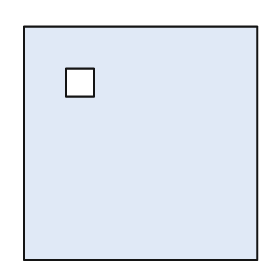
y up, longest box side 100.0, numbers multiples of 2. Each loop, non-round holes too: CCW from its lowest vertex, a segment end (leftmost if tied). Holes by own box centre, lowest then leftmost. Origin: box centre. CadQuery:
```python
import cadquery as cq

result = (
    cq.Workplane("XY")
    .moveTo(-50.0, -50.0)
    .lineTo(50.0, -50.0)
    .lineTo(50.0, 50.0)
    .lineTo(-50.0, 50.0)
    .close()
    .moveTo(-32.0, 20.0)
    .lineTo(-20.0, 20.0)
    .lineTo(-20.0, 32.0)
    .lineTo(-32.0, 32.0)
    .close()
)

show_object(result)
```